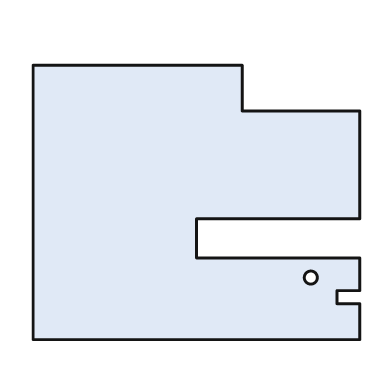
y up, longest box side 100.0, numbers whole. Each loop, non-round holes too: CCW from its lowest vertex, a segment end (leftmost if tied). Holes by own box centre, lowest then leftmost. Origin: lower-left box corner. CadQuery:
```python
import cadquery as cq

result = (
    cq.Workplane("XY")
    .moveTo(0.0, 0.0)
    .lineTo(100.0, 0.0)
    .lineTo(100.0, 11.0)
    .lineTo(93.0, 11.0)
    .lineTo(93.0, 15.0)
    .lineTo(100.0, 15.0)
    .lineTo(100.0, 25.0)
    .lineTo(50.0, 25.0)
    .lineTo(50.0, 37.0)
    .lineTo(100.0, 37.0)
    .lineTo(100.0, 70.0)
    .lineTo(64.0, 70.0)
    .lineTo(64.0, 84.0)
    .lineTo(0.0, 84.0)
    .close()
    .moveTo(85.0, 19.0)
    .circle(2.0)
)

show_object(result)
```